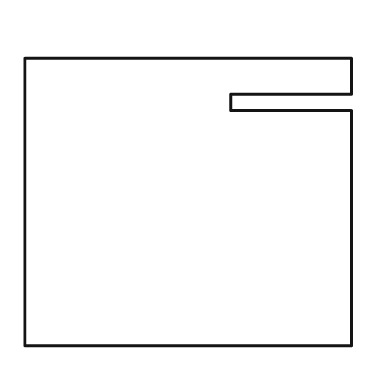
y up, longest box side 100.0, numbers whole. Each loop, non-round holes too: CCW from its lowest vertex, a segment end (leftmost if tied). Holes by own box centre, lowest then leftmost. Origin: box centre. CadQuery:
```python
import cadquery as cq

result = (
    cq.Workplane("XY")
    .moveTo(-50.0, -44.0)
    .lineTo(50.0, -44.0)
    .lineTo(50.0, 28.0)
    .lineTo(13.0, 28.0)
    .lineTo(13.0, 33.0)
    .lineTo(50.0, 33.0)
    .lineTo(50.0, 44.0)
    .lineTo(-50.0, 44.0)
    .close()
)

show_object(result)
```